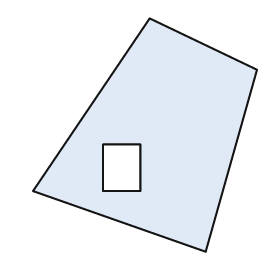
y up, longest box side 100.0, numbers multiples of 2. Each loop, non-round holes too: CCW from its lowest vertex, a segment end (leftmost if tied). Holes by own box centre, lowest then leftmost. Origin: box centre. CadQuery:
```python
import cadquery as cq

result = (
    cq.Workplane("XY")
    .moveTo(26.0, -50.0)
    .lineTo(48.0, 28.0)
    .lineTo(2.0, 50.0)
    .lineTo(-48.0, -24.0)
    .close()
    .moveTo(-18.0, -24.0)
    .lineTo(-2.0, -24.0)
    .lineTo(-2.0, -4.0)
    .lineTo(-18.0, -4.0)
    .close()
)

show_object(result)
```